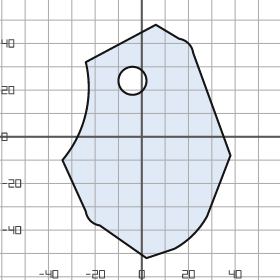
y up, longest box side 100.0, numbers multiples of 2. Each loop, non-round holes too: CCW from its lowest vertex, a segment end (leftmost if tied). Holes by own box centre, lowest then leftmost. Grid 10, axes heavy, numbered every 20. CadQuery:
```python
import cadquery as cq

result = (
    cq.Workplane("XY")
    .moveTo(2.0, -52.0)
    .lineTo(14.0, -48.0)
    .threePointArc((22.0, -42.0), (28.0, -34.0))
    .lineTo(38.0, -8.0)
    .lineTo(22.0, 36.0)
    .threePointArc((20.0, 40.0), (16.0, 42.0))
    .lineTo(6.0, 48.0)
    .lineTo(-24.0, 32.0)
    .threePointArc((-24.0, 10.0), (-34.0, -10.0))
    .lineTo(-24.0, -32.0)
    .threePointArc((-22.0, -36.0), (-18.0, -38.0))
    .close()
    .moveTo(-4.0, 24.0)
    .circle(6.0)
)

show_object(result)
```